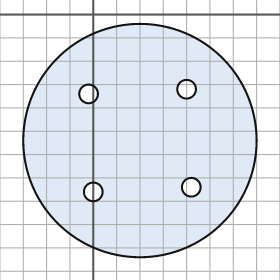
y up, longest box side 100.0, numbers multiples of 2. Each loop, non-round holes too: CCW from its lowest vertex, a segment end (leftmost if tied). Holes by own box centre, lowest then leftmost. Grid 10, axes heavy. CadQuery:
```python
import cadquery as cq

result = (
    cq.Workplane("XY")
    .moveTo(20.0, -54.0)
    .circle(50.0)
    .moveTo(0.0, -76.0)
    .circle(4.0)
    .moveTo(42.0, -74.0)
    .circle(4.0)
    .moveTo(-2.0, -34.0)
    .circle(4.0)
    .moveTo(40.0, -32.0)
    .circle(4.0)
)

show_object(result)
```